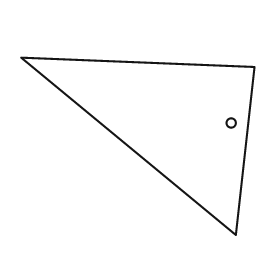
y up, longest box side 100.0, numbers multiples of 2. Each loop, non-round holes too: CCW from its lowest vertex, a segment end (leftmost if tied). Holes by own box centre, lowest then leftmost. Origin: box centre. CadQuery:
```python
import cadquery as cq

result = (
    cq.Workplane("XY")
    .moveTo(42.0, -38.0)
    .lineTo(50.0, 34.0)
    .lineTo(-50.0, 38.0)
    .close()
    .moveTo(40.0, 10.0)
    .circle(2.0)
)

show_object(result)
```